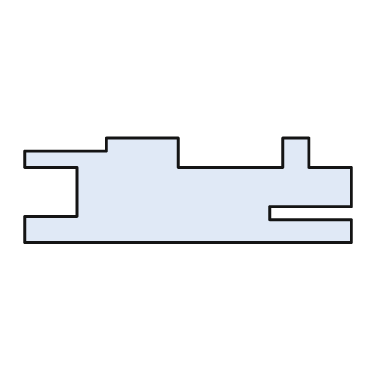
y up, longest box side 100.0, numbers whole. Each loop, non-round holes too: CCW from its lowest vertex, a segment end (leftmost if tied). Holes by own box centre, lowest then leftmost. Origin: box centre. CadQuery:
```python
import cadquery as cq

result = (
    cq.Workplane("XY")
    .moveTo(-50.0, -16.0)
    .lineTo(50.0, -16.0)
    .lineTo(50.0, -9.0)
    .lineTo(25.0, -9.0)
    .lineTo(25.0, -5.0)
    .lineTo(50.0, -5.0)
    .lineTo(50.0, 7.0)
    .lineTo(37.0, 7.0)
    .lineTo(37.0, 16.0)
    .lineTo(29.0, 16.0)
    .lineTo(29.0, 7.0)
    .lineTo(-3.0, 7.0)
    .lineTo(-3.0, 16.0)
    .lineTo(-25.0, 16.0)
    .lineTo(-25.0, 12.0)
    .lineTo(-50.0, 12.0)
    .lineTo(-50.0, 7.0)
    .lineTo(-34.0, 7.0)
    .lineTo(-34.0, -8.0)
    .lineTo(-50.0, -8.0)
    .close()
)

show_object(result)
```